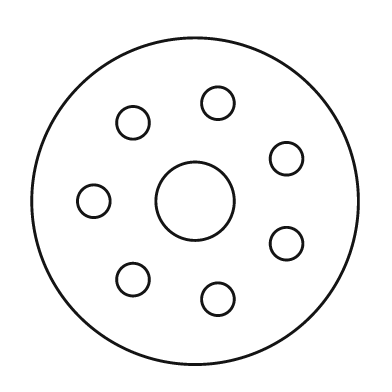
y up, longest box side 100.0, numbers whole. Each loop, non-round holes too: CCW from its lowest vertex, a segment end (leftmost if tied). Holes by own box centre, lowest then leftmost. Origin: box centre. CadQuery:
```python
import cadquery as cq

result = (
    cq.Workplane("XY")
    .moveTo(0.0, 0.0)
    .circle(50.0)
    .moveTo(7.0, -30.0)
    .circle(5.0)
    .moveTo(-19.0, -24.0)
    .circle(5.0)
    .moveTo(28.0, -13.0)
    .circle(5.0)
    .moveTo(-31.0, 0.0)
    .circle(5.0)
    .moveTo(0.0, 0.0)
    .circle(12.0)
    .moveTo(28.0, 13.0)
    .circle(5.0)
    .moveTo(-19.0, 24.0)
    .circle(5.0)
    .moveTo(7.0, 30.0)
    .circle(5.0)
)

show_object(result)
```